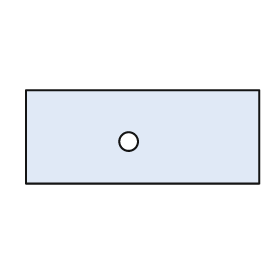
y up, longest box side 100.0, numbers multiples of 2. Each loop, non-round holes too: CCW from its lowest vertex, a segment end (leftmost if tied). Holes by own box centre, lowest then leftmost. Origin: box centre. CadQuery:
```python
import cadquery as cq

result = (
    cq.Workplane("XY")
    .moveTo(-50.0, -20.0)
    .lineTo(50.0, -20.0)
    .lineTo(50.0, 20.0)
    .lineTo(-50.0, 20.0)
    .close()
    .moveTo(-6.0, -2.0)
    .circle(4.0)
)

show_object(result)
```